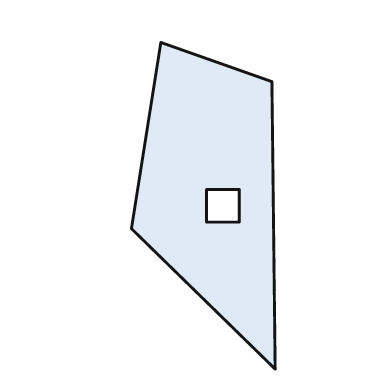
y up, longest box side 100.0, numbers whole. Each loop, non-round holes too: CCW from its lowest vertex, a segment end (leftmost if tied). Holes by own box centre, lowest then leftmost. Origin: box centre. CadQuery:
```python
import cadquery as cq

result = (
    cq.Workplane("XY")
    .moveTo(22.0, -50.0)
    .lineTo(21.0, 38.0)
    .lineTo(-13.0, 50.0)
    .lineTo(-22.0, -7.0)
    .close()
    .moveTo(1.0, -5.0)
    .lineTo(11.0, -5.0)
    .lineTo(11.0, 5.0)
    .lineTo(1.0, 5.0)
    .close()
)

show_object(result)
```